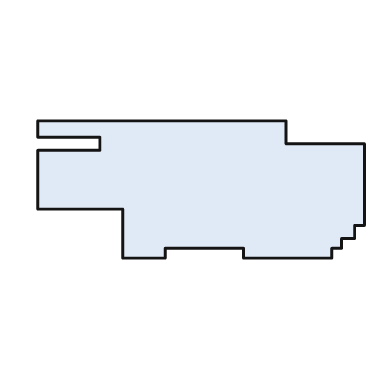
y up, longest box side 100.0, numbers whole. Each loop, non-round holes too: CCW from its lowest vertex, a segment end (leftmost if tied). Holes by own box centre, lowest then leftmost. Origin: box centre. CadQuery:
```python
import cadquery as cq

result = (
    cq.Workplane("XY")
    .moveTo(-24.0, -21.0)
    .lineTo(-11.0, -21.0)
    .lineTo(-11.0, -18.0)
    .lineTo(13.0, -18.0)
    .lineTo(13.0, -21.0)
    .lineTo(40.0, -21.0)
    .lineTo(40.0, -18.0)
    .lineTo(43.0, -18.0)
    .lineTo(43.0, -15.0)
    .lineTo(47.0, -15.0)
    .lineTo(47.0, -11.0)
    .lineTo(50.0, -11.0)
    .lineTo(50.0, 14.0)
    .lineTo(26.0, 14.0)
    .lineTo(26.0, 21.0)
    .lineTo(-50.0, 21.0)
    .lineTo(-50.0, 16.0)
    .lineTo(-31.0, 16.0)
    .lineTo(-31.0, 12.0)
    .lineTo(-50.0, 12.0)
    .lineTo(-50.0, -6.0)
    .lineTo(-24.0, -6.0)
    .close()
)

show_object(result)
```